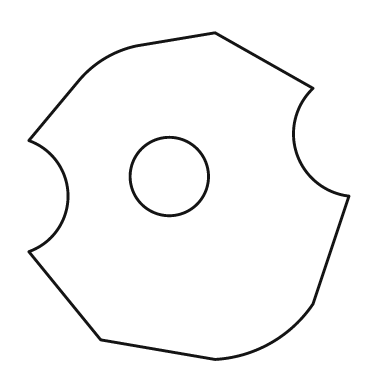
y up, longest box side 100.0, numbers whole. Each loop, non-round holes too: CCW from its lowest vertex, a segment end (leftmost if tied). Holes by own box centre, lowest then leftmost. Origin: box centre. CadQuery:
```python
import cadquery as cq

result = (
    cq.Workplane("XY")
    .moveTo(8.0, -50.0)
    .threePointArc((25.0, -45.0), (38.0, -33.0))
    .lineTo(49.0, 0.0)
    .threePointArc((33.0, 13.0), (38.0, 33.0))
    .lineTo(8.0, 50.0)
    .lineTo(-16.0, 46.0)
    .threePointArc((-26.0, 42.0), (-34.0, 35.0))
    .lineTo(-49.0, 17.0)
    .threePointArc((-37.0, 0.0), (-49.0, -17.0))
    .lineTo(-27.0, -44.0)
    .close()
    .moveTo(-6.0, 6.0)
    .circle(12.0)
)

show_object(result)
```